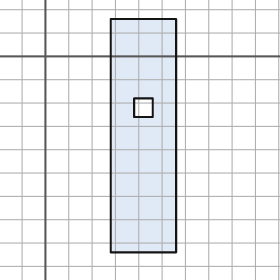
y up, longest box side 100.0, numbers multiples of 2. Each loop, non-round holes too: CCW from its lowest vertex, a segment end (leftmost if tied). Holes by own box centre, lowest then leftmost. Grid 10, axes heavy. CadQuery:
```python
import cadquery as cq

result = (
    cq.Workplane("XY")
    .moveTo(28.0, -84.0)
    .lineTo(56.0, -84.0)
    .lineTo(56.0, 16.0)
    .lineTo(28.0, 16.0)
    .close()
    .moveTo(38.0, -26.0)
    .lineTo(46.0, -26.0)
    .lineTo(46.0, -18.0)
    .lineTo(38.0, -18.0)
    .close()
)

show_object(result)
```